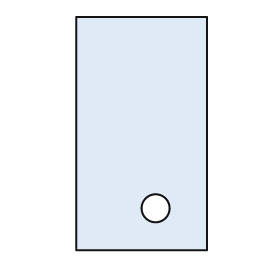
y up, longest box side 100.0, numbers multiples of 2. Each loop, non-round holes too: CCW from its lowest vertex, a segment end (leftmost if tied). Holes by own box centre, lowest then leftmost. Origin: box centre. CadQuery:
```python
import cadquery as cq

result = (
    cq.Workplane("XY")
    .moveTo(-28.0, -50.0)
    .lineTo(28.0, -50.0)
    .lineTo(28.0, 50.0)
    .lineTo(-28.0, 50.0)
    .close()
    .moveTo(6.0, -32.0)
    .circle(6.0)
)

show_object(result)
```